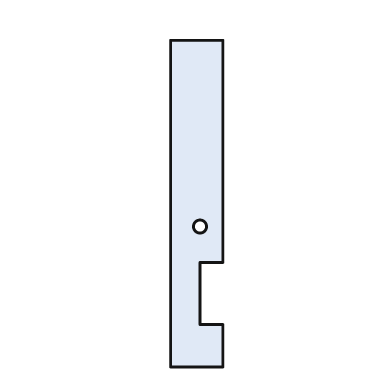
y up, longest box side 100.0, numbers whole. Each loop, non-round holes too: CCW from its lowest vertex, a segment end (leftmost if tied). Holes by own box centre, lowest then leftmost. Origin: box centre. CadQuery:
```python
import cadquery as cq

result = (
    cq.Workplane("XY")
    .moveTo(-8.0, -50.0)
    .lineTo(8.0, -50.0)
    .lineTo(8.0, -37.0)
    .lineTo(1.0, -37.0)
    .lineTo(1.0, -18.0)
    .lineTo(8.0, -18.0)
    .lineTo(8.0, 50.0)
    .lineTo(-8.0, 50.0)
    .close()
    .moveTo(1.0, -7.0)
    .circle(2.0)
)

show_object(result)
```